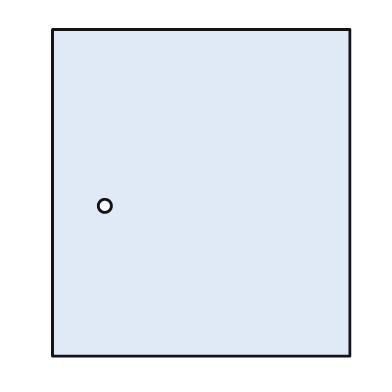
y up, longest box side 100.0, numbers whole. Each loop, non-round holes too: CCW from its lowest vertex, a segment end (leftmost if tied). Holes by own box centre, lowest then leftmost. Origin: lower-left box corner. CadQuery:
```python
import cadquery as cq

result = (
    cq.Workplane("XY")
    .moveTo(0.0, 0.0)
    .lineTo(91.0, 0.0)
    .lineTo(91.0, 100.0)
    .lineTo(0.0, 100.0)
    .close()
    .moveTo(16.0, 46.0)
    .circle(2.0)
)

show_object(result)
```